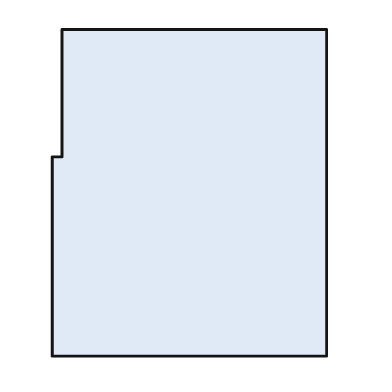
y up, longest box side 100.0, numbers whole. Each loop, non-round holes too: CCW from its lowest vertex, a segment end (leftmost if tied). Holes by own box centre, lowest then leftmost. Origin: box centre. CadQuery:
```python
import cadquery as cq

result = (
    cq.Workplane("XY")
    .moveTo(-42.0, -50.0)
    .lineTo(42.0, -50.0)
    .lineTo(42.0, 50.0)
    .lineTo(-39.0, 50.0)
    .lineTo(-39.0, 11.0)
    .lineTo(-42.0, 11.0)
    .close()
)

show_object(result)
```